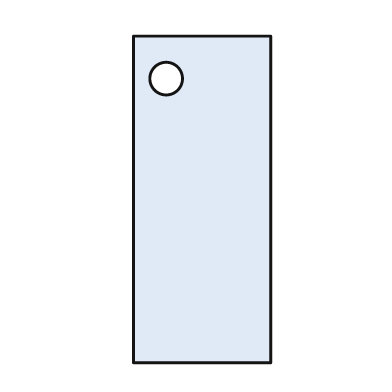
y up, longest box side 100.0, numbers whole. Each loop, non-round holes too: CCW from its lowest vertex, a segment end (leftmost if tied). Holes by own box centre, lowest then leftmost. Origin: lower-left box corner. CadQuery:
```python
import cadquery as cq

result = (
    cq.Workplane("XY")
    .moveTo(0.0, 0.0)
    .lineTo(42.0, 0.0)
    .lineTo(42.0, 100.0)
    .lineTo(0.0, 100.0)
    .close()
    .moveTo(10.0, 87.0)
    .circle(5.0)
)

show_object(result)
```